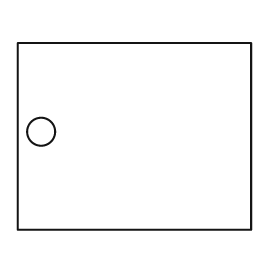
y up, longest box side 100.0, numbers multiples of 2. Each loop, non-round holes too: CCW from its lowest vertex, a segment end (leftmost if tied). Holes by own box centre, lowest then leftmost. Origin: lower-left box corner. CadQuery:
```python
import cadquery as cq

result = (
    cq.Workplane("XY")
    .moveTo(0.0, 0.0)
    .lineTo(100.0, 0.0)
    .lineTo(100.0, 80.0)
    .lineTo(0.0, 80.0)
    .close()
    .moveTo(10.0, 42.0)
    .circle(6.0)
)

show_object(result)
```